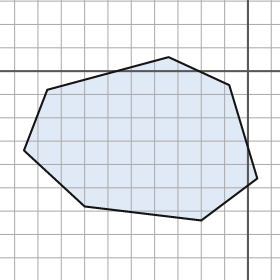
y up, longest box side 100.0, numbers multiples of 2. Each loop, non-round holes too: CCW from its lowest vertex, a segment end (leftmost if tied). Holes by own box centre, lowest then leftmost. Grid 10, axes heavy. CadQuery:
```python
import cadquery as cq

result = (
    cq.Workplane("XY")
    .moveTo(-20.0, -64.0)
    .lineTo(4.0, -46.0)
    .lineTo(-8.0, -6.0)
    .lineTo(-34.0, 6.0)
    .lineTo(-86.0, -8.0)
    .lineTo(-96.0, -34.0)
    .lineTo(-70.0, -58.0)
    .close()
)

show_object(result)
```